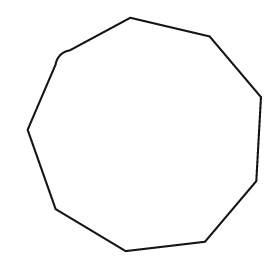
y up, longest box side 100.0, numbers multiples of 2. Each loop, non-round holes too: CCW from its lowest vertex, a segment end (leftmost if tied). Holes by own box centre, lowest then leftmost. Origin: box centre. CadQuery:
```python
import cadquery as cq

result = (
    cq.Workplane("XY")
    .moveTo(-8.0, -50.0)
    .lineTo(26.0, -46.0)
    .lineTo(48.0, -20.0)
    .lineTo(50.0, 16.0)
    .lineTo(28.0, 42.0)
    .lineTo(-6.0, 50.0)
    .lineTo(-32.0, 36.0)
    .threePointArc((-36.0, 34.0), (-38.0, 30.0))
    .lineTo(-50.0, 2.0)
    .lineTo(-38.0, -32.0)
    .close()
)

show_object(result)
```